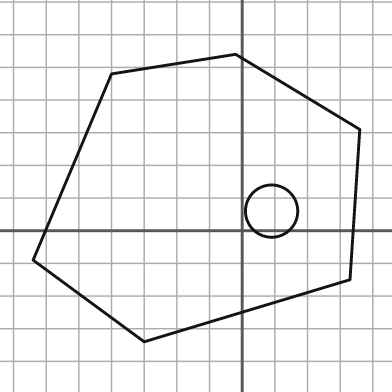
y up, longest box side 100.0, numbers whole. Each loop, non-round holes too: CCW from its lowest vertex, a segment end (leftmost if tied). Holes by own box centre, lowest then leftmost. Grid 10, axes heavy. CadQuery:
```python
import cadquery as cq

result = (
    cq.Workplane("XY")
    .moveTo(-30.0, -34.0)
    .lineTo(33.0, -15.0)
    .lineTo(36.0, 31.0)
    .lineTo(-2.0, 54.0)
    .lineTo(-40.0, 48.0)
    .lineTo(-64.0, -9.0)
    .close()
    .moveTo(9.0, 6.0)
    .circle(8.0)
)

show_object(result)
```